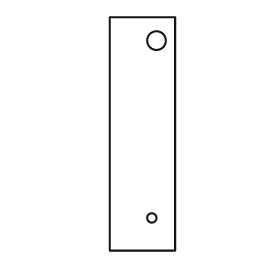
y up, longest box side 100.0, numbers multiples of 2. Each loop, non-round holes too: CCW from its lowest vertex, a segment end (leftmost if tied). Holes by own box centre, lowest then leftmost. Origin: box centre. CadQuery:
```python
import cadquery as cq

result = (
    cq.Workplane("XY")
    .moveTo(-14.0, -50.0)
    .lineTo(14.0, -50.0)
    .lineTo(14.0, 50.0)
    .lineTo(-14.0, 50.0)
    .close()
    .moveTo(4.0, -36.0)
    .circle(2.0)
    .moveTo(6.0, 40.0)
    .circle(4.0)
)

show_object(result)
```